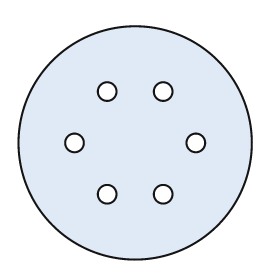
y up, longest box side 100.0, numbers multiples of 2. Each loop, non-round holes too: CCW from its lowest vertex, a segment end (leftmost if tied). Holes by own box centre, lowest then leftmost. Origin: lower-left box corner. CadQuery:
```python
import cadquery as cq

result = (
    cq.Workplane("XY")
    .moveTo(50.0, 50.0)
    .circle(50.0)
    .moveTo(38.0, 28.0)
    .circle(4.0)
    .moveTo(62.0, 28.0)
    .circle(4.0)
    .moveTo(24.0, 50.0)
    .circle(4.0)
    .moveTo(76.0, 50.0)
    .circle(4.0)
    .moveTo(38.0, 72.0)
    .circle(4.0)
    .moveTo(62.0, 72.0)
    .circle(4.0)
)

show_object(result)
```